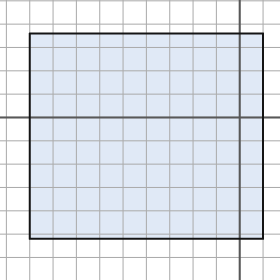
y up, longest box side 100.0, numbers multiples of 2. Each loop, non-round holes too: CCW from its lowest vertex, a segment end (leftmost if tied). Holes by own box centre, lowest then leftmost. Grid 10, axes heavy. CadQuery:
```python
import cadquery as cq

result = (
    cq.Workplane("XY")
    .moveTo(-90.0, -52.0)
    .lineTo(10.0, -52.0)
    .lineTo(10.0, 36.0)
    .lineTo(-90.0, 36.0)
    .close()
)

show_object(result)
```